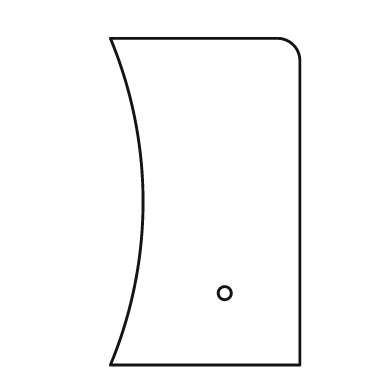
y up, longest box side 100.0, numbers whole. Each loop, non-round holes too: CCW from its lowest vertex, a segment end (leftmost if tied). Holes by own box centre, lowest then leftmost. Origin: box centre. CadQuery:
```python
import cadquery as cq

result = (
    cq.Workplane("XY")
    .moveTo(-29.0, -50.0)
    .lineTo(29.0, -50.0)
    .lineTo(29.0, 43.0)
    .threePointArc((27.0, 48.0), (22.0, 50.0))
    .lineTo(-29.0, 50.0)
    .threePointArc((-19.0, 0.0), (-29.0, -50.0))
    .close()
    .moveTo(6.0, -28.0)
    .circle(2.0)
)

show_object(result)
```